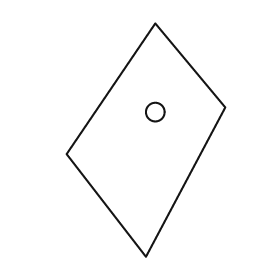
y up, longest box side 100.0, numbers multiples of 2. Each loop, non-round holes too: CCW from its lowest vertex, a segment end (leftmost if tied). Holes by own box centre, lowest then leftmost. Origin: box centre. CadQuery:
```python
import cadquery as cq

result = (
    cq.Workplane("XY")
    .moveTo(0.0, -50.0)
    .lineTo(34.0, 14.0)
    .lineTo(4.0, 50.0)
    .lineTo(-34.0, -6.0)
    .close()
    .moveTo(4.0, 12.0)
    .circle(4.0)
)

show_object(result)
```